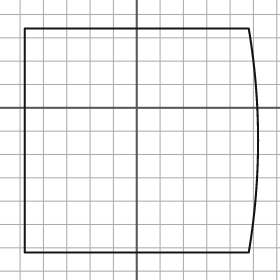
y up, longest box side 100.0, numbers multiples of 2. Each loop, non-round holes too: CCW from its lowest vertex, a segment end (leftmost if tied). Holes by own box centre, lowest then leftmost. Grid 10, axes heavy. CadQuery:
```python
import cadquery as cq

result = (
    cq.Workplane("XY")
    .moveTo(-48.0, -62.0)
    .lineTo(48.0, -62.0)
    .threePointArc((52.0, -14.0), (48.0, 34.0))
    .lineTo(-48.0, 34.0)
    .close()
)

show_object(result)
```